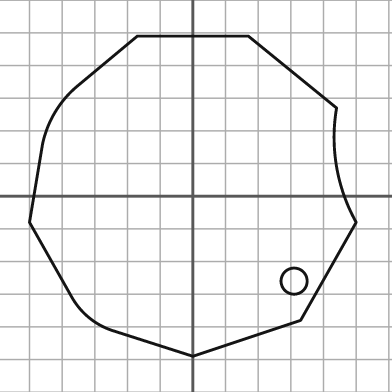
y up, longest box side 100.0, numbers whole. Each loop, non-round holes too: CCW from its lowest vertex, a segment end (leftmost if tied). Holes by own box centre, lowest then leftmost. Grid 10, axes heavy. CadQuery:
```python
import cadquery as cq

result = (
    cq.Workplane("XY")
    .moveTo(0.0, -49.0)
    .lineTo(33.0, -38.0)
    .lineTo(50.0, -8.0)
    .threePointArc((44.0, 9.0), (44.0, 27.0))
    .lineTo(17.0, 49.0)
    .lineTo(-17.0, 49.0)
    .lineTo(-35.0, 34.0)
    .threePointArc((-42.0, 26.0), (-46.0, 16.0))
    .lineTo(-50.0, -8.0)
    .lineTo(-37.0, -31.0)
    .threePointArc((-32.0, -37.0), (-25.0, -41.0))
    .close()
    .moveTo(31.0, -26.0)
    .circle(4.0)
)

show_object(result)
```